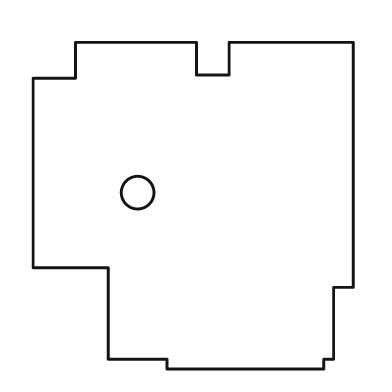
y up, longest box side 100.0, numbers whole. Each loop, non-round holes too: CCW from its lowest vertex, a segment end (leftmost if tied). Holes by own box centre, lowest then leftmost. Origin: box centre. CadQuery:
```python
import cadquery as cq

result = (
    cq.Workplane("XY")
    .moveTo(-8.0, -50.0)
    .lineTo(40.0, -50.0)
    .lineTo(40.0, -47.0)
    .lineTo(43.0, -47.0)
    .lineTo(43.0, -25.0)
    .lineTo(49.0, -25.0)
    .lineTo(49.0, 50.0)
    .lineTo(11.0, 50.0)
    .lineTo(11.0, 40.0)
    .lineTo(1.0, 40.0)
    .lineTo(1.0, 50.0)
    .lineTo(-36.0, 50.0)
    .lineTo(-36.0, 39.0)
    .lineTo(-49.0, 39.0)
    .lineTo(-49.0, -19.0)
    .lineTo(-26.0, -19.0)
    .lineTo(-26.0, -47.0)
    .lineTo(-8.0, -47.0)
    .close()
    .moveTo(-17.0, 4.0)
    .circle(5.0)
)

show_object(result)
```